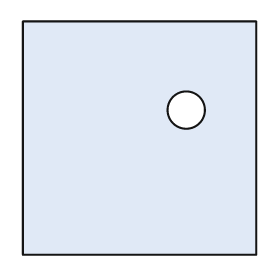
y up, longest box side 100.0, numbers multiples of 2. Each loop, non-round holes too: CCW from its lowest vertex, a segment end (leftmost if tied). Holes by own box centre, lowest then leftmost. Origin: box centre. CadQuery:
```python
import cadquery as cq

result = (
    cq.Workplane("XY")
    .moveTo(-50.0, -50.0)
    .lineTo(50.0, -50.0)
    .lineTo(50.0, 50.0)
    .lineTo(-50.0, 50.0)
    .close()
    .moveTo(20.0, 12.0)
    .circle(8.0)
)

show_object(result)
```